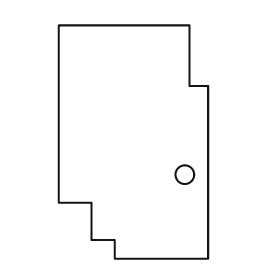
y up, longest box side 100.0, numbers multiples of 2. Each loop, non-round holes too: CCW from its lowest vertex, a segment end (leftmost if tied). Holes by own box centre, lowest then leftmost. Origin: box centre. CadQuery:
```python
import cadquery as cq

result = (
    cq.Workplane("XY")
    .moveTo(-8.0, -50.0)
    .lineTo(32.0, -50.0)
    .lineTo(32.0, 24.0)
    .lineTo(24.0, 24.0)
    .lineTo(24.0, 50.0)
    .lineTo(-32.0, 50.0)
    .lineTo(-32.0, -26.0)
    .lineTo(-18.0, -26.0)
    .lineTo(-18.0, -42.0)
    .lineTo(-8.0, -42.0)
    .close()
    .moveTo(22.0, -14.0)
    .circle(4.0)
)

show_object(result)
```